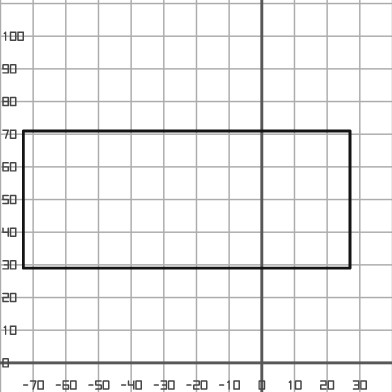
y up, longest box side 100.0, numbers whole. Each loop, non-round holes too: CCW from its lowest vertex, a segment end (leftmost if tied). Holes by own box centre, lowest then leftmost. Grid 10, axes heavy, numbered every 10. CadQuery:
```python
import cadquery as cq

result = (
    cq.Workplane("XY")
    .moveTo(-73.0, 29.0)
    .lineTo(27.0, 29.0)
    .lineTo(27.0, 71.0)
    .lineTo(-73.0, 71.0)
    .close()
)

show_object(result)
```